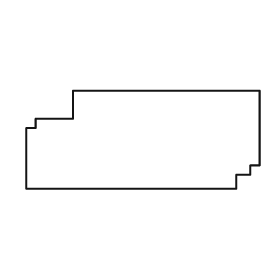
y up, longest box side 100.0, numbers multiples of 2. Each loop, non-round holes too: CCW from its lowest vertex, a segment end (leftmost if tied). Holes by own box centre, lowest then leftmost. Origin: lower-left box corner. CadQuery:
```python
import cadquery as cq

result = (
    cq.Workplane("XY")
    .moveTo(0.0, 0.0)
    .lineTo(90.0, 0.0)
    .lineTo(90.0, 6.0)
    .lineTo(96.0, 6.0)
    .lineTo(96.0, 10.0)
    .lineTo(100.0, 10.0)
    .lineTo(100.0, 42.0)
    .lineTo(20.0, 42.0)
    .lineTo(20.0, 30.0)
    .lineTo(4.0, 30.0)
    .lineTo(4.0, 26.0)
    .lineTo(0.0, 26.0)
    .close()
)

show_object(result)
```